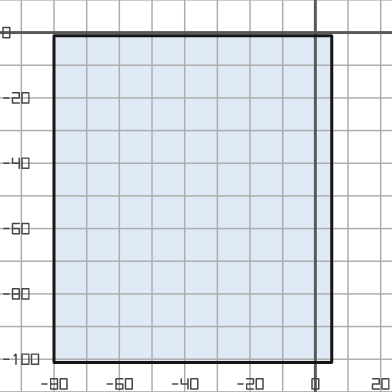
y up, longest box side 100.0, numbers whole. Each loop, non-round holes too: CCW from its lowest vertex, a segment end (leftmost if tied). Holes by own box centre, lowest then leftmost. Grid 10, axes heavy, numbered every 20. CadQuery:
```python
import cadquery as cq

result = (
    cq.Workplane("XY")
    .moveTo(-80.0, -101.0)
    .lineTo(5.0, -101.0)
    .lineTo(5.0, -1.0)
    .lineTo(-80.0, -1.0)
    .close()
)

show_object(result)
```